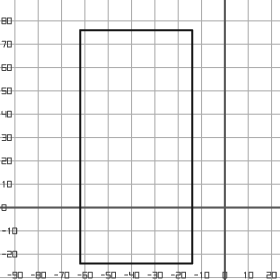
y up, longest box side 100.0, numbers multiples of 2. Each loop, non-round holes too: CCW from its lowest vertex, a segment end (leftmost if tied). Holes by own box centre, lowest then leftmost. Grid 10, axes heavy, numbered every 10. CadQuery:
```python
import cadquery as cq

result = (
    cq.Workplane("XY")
    .moveTo(-62.0, -24.0)
    .lineTo(-14.0, -24.0)
    .lineTo(-14.0, 76.0)
    .lineTo(-62.0, 76.0)
    .close()
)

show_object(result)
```